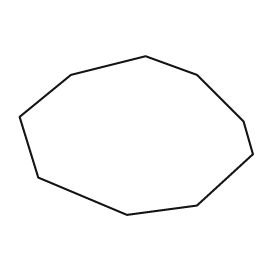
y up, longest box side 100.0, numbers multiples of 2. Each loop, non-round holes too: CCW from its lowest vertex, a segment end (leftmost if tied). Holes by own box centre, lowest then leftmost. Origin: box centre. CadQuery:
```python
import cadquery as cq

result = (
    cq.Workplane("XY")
    .moveTo(-4.0, -34.0)
    .lineTo(26.0, -30.0)
    .lineTo(50.0, -8.0)
    .lineTo(46.0, 6.0)
    .lineTo(26.0, 26.0)
    .lineTo(4.0, 34.0)
    .lineTo(-28.0, 26.0)
    .lineTo(-50.0, 8.0)
    .lineTo(-42.0, -18.0)
    .close()
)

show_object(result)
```